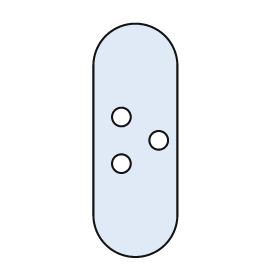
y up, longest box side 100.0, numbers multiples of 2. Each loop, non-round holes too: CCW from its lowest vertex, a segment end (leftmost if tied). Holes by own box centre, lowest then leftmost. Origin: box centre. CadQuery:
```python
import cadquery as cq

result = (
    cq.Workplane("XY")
    .moveTo(-18.0, -32.0)
    .threePointArc((0.0, -50.0), (18.0, -32.0))
    .lineTo(18.0, 32.0)
    .threePointArc((0.0, 50.0), (-18.0, 32.0))
    .close()
    .moveTo(-6.0, -10.0)
    .circle(4.0)
    .moveTo(10.0, 0.0)
    .circle(4.0)
    .moveTo(-6.0, 10.0)
    .circle(4.0)
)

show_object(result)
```